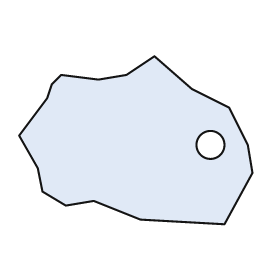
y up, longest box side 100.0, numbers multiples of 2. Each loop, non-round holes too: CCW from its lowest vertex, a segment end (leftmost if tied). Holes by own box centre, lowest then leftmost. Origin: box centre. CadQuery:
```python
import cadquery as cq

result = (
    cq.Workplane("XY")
    .moveTo(38.0, -36.0)
    .lineTo(50.0, -14.0)
    .lineTo(48.0, -2.0)
    .lineTo(40.0, 14.0)
    .lineTo(24.0, 22.0)
    .lineTo(8.0, 36.0)
    .lineTo(-4.0, 28.0)
    .lineTo(-16.0, 26.0)
    .lineTo(-32.0, 28.0)
    .lineTo(-36.0, 24.0)
    .lineTo(-38.0, 18.0)
    .lineTo(-50.0, 2.0)
    .lineTo(-42.0, -12.0)
    .lineTo(-40.0, -22.0)
    .lineTo(-30.0, -28.0)
    .lineTo(-18.0, -26.0)
    .lineTo(2.0, -34.0)
    .close()
    .moveTo(32.0, -2.0)
    .circle(6.0)
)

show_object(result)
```